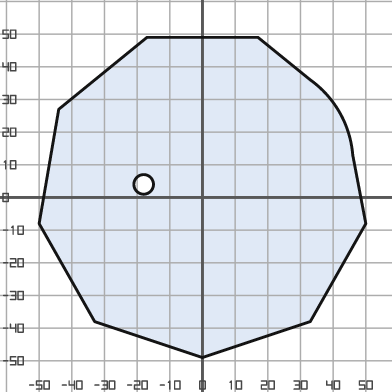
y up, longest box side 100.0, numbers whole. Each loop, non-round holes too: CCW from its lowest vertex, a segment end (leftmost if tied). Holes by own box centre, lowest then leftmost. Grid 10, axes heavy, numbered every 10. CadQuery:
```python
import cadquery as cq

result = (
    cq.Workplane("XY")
    .moveTo(0.0, -49.0)
    .lineTo(33.0, -38.0)
    .lineTo(50.0, -8.0)
    .lineTo(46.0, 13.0)
    .threePointArc((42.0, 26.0), (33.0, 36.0))
    .lineTo(17.0, 49.0)
    .lineTo(-17.0, 49.0)
    .lineTo(-44.0, 27.0)
    .lineTo(-50.0, -8.0)
    .lineTo(-33.0, -38.0)
    .close()
    .moveTo(-18.0, 4.0)
    .circle(3.0)
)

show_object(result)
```